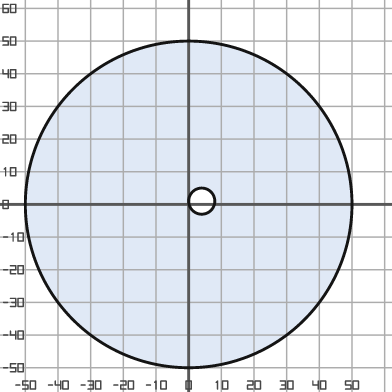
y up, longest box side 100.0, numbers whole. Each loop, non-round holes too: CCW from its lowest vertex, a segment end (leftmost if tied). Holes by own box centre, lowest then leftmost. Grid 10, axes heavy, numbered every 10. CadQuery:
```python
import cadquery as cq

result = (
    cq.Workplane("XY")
    .moveTo(0.0, 0.0)
    .circle(50.0)
    .moveTo(4.0, 1.0)
    .circle(4.0)
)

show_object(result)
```